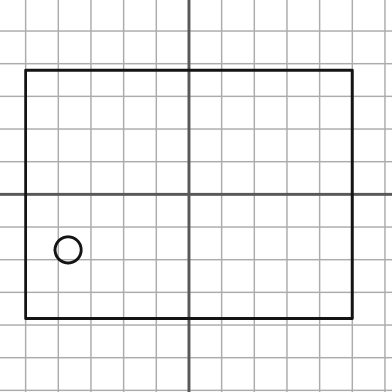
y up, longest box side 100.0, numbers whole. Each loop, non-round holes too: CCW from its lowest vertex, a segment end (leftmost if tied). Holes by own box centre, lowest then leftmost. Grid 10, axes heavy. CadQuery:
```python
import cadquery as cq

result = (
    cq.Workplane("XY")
    .moveTo(-50.0, -38.0)
    .lineTo(50.0, -38.0)
    .lineTo(50.0, 38.0)
    .lineTo(-50.0, 38.0)
    .close()
    .moveTo(-37.0, -17.0)
    .circle(4.0)
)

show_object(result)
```